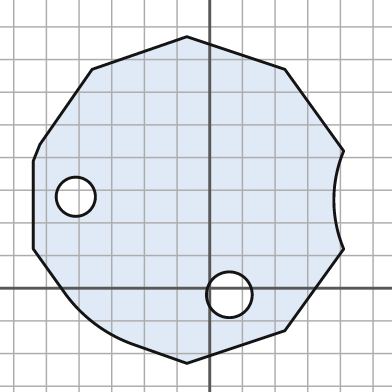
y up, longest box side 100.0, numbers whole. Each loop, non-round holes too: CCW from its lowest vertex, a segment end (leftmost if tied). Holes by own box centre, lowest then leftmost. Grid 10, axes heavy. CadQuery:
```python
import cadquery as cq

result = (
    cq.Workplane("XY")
    .moveTo(-7.0, -23.0)
    .lineTo(23.0, -13.0)
    .lineTo(41.0, 12.0)
    .threePointArc((38.0, 27.0), (41.0, 42.0))
    .lineTo(23.0, 67.0)
    .lineTo(-7.0, 77.0)
    .lineTo(-36.0, 67.0)
    .lineTo(-52.0, 44.0)
    .lineTo(-54.0, 39.0)
    .lineTo(-54.0, 12.0)
    .lineTo(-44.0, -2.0)
    .threePointArc((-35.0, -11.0), (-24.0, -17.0))
    .close()
    .moveTo(6.0, -2.0)
    .circle(7.0)
    .moveTo(-41.0, 28.0)
    .circle(6.0)
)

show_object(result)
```